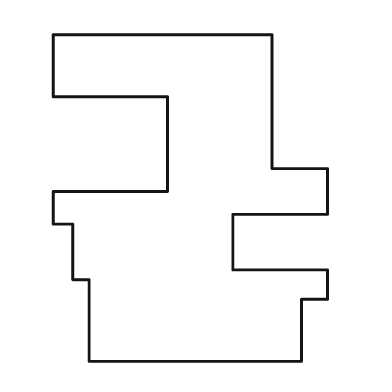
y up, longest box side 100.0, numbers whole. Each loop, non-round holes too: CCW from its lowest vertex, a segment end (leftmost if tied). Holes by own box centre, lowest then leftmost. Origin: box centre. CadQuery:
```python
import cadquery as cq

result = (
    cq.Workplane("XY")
    .moveTo(-31.0, -50.0)
    .lineTo(34.0, -50.0)
    .lineTo(34.0, -31.0)
    .lineTo(42.0, -31.0)
    .lineTo(42.0, -22.0)
    .lineTo(13.0, -22.0)
    .lineTo(13.0, -5.0)
    .lineTo(42.0, -5.0)
    .lineTo(42.0, 9.0)
    .lineTo(25.0, 9.0)
    .lineTo(25.0, 50.0)
    .lineTo(-42.0, 50.0)
    .lineTo(-42.0, 31.0)
    .lineTo(-7.0, 31.0)
    .lineTo(-7.0, 2.0)
    .lineTo(-42.0, 2.0)
    .lineTo(-42.0, -8.0)
    .lineTo(-36.0, -8.0)
    .lineTo(-36.0, -25.0)
    .lineTo(-31.0, -25.0)
    .close()
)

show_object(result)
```